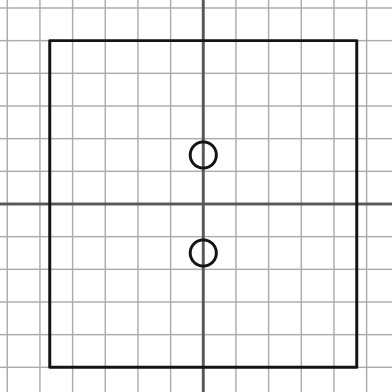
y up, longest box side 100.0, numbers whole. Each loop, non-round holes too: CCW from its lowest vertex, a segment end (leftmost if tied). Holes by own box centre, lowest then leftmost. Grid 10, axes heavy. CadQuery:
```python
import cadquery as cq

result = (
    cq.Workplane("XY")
    .moveTo(-47.0, -50.0)
    .lineTo(47.0, -50.0)
    .lineTo(47.0, 50.0)
    .lineTo(-47.0, 50.0)
    .close()
    .moveTo(0.0, -15.0)
    .circle(4.0)
    .moveTo(0.0, 15.0)
    .circle(4.0)
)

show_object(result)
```